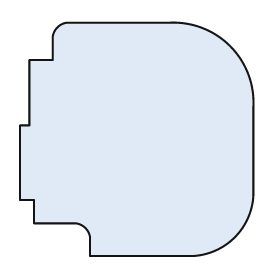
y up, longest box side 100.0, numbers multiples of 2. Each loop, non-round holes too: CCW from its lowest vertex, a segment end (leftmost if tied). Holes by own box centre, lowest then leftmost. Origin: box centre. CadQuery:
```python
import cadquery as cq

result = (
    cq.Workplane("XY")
    .moveTo(-20.0, -50.0)
    .lineTo(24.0, -50.0)
    .threePointArc((42.0, -42.0), (50.0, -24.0))
    .lineTo(50.0, 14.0)
    .threePointArc((40.0, 40.0), (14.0, 50.0))
    .lineTo(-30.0, 50.0)
    .threePointArc((-34.0, 48.0), (-36.0, 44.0))
    .lineTo(-36.0, 34.0)
    .lineTo(-46.0, 34.0)
    .lineTo(-46.0, 6.0)
    .lineTo(-50.0, 6.0)
    .lineTo(-50.0, -26.0)
    .lineTo(-44.0, -26.0)
    .lineTo(-44.0, -36.0)
    .lineTo(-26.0, -36.0)
    .threePointArc((-22.0, -38.0), (-20.0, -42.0))
    .close()
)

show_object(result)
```